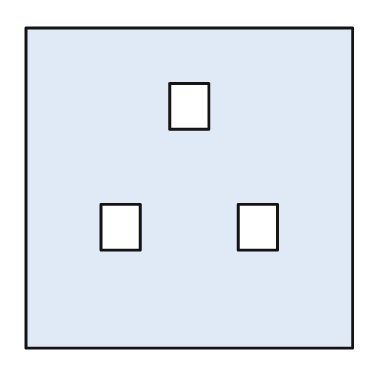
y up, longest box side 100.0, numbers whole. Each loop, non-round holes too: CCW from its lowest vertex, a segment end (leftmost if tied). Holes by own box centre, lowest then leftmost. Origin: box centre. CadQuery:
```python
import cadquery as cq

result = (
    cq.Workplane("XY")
    .moveTo(-50.0, -49.0)
    .lineTo(50.0, -49.0)
    .lineTo(50.0, 49.0)
    .lineTo(-50.0, 49.0)
    .close()
    .moveTo(-27.0, -19.0)
    .lineTo(-15.0, -19.0)
    .lineTo(-15.0, -5.0)
    .lineTo(-27.0, -5.0)
    .close()
    .moveTo(15.0, -19.0)
    .lineTo(27.0, -19.0)
    .lineTo(27.0, -5.0)
    .lineTo(15.0, -5.0)
    .close()
    .moveTo(-6.0, 18.0)
    .lineTo(6.0, 18.0)
    .lineTo(6.0, 32.0)
    .lineTo(-6.0, 32.0)
    .close()
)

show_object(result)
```